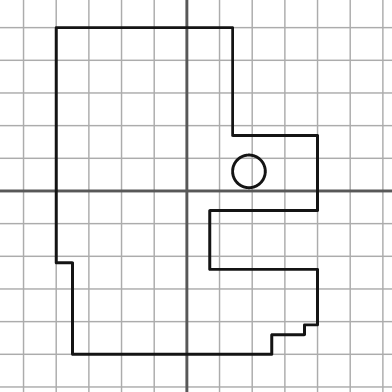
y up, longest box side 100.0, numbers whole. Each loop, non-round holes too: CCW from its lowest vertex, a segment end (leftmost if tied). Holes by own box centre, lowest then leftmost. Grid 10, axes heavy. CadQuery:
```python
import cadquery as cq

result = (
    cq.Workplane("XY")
    .moveTo(-35.0, -50.0)
    .lineTo(26.0, -50.0)
    .lineTo(26.0, -44.0)
    .lineTo(36.0, -44.0)
    .lineTo(36.0, -41.0)
    .lineTo(40.0, -41.0)
    .lineTo(40.0, -24.0)
    .lineTo(7.0, -24.0)
    .lineTo(7.0, -6.0)
    .lineTo(40.0, -6.0)
    .lineTo(40.0, 17.0)
    .lineTo(14.0, 17.0)
    .lineTo(14.0, 50.0)
    .lineTo(-40.0, 50.0)
    .lineTo(-40.0, -22.0)
    .lineTo(-35.0, -22.0)
    .close()
    .moveTo(19.0, 6.0)
    .circle(5.0)
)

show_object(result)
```